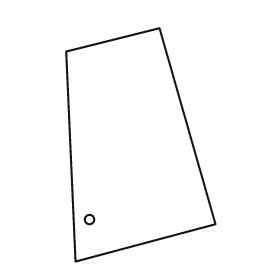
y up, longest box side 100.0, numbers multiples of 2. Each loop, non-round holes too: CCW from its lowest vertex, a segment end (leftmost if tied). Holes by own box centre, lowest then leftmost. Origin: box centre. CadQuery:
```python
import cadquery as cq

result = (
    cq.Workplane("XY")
    .moveTo(-28.0, -50.0)
    .lineTo(32.0, -34.0)
    .lineTo(8.0, 50.0)
    .lineTo(-32.0, 40.0)
    .close()
    .moveTo(-22.0, -32.0)
    .circle(2.0)
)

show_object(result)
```